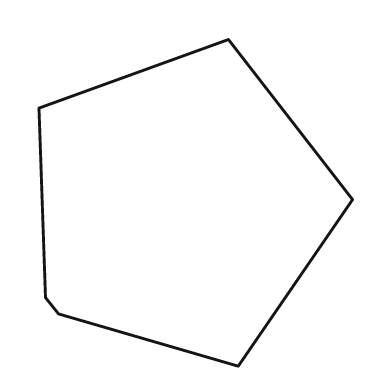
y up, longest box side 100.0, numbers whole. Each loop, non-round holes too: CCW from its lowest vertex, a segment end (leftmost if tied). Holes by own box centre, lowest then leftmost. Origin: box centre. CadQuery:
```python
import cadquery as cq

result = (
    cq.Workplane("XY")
    .moveTo(13.0, -50.0)
    .lineTo(48.0, 1.0)
    .lineTo(10.0, 50.0)
    .lineTo(-48.0, 29.0)
    .lineTo(-46.0, -29.0)
    .lineTo(-42.0, -34.0)
    .close()
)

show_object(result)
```